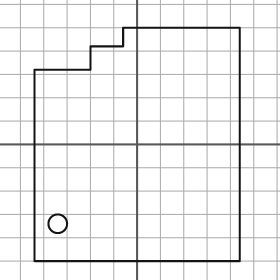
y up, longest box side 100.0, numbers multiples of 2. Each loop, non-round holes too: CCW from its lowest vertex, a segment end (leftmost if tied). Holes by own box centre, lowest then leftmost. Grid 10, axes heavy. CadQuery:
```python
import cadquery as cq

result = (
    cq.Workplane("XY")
    .moveTo(-44.0, -50.0)
    .lineTo(44.0, -50.0)
    .lineTo(44.0, 50.0)
    .lineTo(-6.0, 50.0)
    .lineTo(-6.0, 42.0)
    .lineTo(-20.0, 42.0)
    .lineTo(-20.0, 32.0)
    .lineTo(-44.0, 32.0)
    .close()
    .moveTo(-34.0, -34.0)
    .circle(4.0)
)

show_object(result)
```